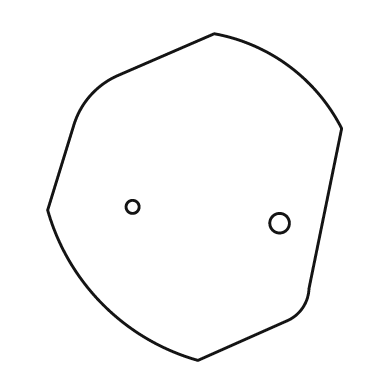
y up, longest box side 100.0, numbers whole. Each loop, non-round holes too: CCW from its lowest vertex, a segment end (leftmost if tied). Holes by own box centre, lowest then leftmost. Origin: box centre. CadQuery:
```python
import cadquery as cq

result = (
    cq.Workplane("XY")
    .moveTo(1.0, -50.0)
    .lineTo(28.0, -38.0)
    .threePointArc((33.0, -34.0), (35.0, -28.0))
    .lineTo(45.0, 21.0)
    .threePointArc((29.0, 40.0), (6.0, 50.0))
    .lineTo(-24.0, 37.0)
    .threePointArc((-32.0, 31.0), (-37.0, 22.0))
    .lineTo(-45.0, -4.0)
    .threePointArc((-28.0, -33.0), (1.0, -50.0))
    .close()
    .moveTo(26.0, -8.0)
    .circle(3.0)
    .moveTo(-19.0, -3.0)
    .circle(2.0)
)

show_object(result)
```